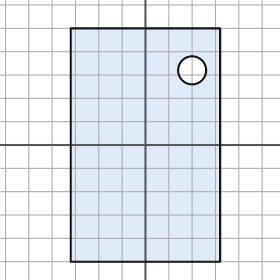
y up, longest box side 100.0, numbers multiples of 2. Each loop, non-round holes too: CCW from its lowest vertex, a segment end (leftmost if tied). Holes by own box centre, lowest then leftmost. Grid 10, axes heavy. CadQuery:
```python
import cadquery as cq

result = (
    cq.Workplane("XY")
    .moveTo(-32.0, -50.0)
    .lineTo(32.0, -50.0)
    .lineTo(32.0, 50.0)
    .lineTo(-32.0, 50.0)
    .close()
    .moveTo(20.0, 32.0)
    .circle(6.0)
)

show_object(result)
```